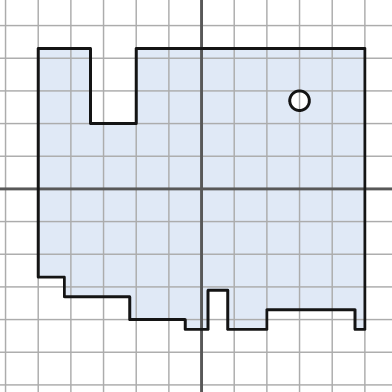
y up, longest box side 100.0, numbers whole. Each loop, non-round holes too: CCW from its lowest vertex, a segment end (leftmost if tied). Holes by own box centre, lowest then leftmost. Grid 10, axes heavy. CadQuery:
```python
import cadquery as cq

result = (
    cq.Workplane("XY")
    .moveTo(-5.0, -43.0)
    .lineTo(2.0, -43.0)
    .lineTo(2.0, -31.0)
    .lineTo(8.0, -31.0)
    .lineTo(8.0, -43.0)
    .lineTo(20.0, -43.0)
    .lineTo(20.0, -37.0)
    .lineTo(47.0, -37.0)
    .lineTo(47.0, -43.0)
    .lineTo(50.0, -43.0)
    .lineTo(50.0, 43.0)
    .lineTo(-20.0, 43.0)
    .lineTo(-20.0, 20.0)
    .lineTo(-34.0, 20.0)
    .lineTo(-34.0, 43.0)
    .lineTo(-50.0, 43.0)
    .lineTo(-50.0, -27.0)
    .lineTo(-42.0, -27.0)
    .lineTo(-42.0, -33.0)
    .lineTo(-22.0, -33.0)
    .lineTo(-22.0, -40.0)
    .lineTo(-5.0, -40.0)
    .close()
    .moveTo(30.0, 27.0)
    .circle(3.0)
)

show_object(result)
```